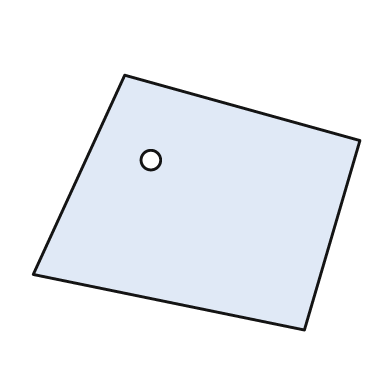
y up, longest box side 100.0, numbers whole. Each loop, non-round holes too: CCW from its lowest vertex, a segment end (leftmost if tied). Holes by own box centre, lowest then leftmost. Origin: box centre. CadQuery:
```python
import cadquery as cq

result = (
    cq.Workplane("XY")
    .moveTo(33.0, -39.0)
    .lineTo(50.0, 19.0)
    .lineTo(-22.0, 39.0)
    .lineTo(-50.0, -22.0)
    .close()
    .moveTo(-14.0, 13.0)
    .circle(3.0)
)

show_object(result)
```